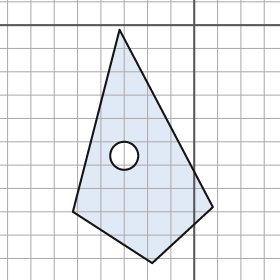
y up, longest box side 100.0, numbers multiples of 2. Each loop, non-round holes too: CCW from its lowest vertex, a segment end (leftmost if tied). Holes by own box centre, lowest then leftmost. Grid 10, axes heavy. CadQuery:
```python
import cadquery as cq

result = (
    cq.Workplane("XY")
    .moveTo(-18.0, -102.0)
    .lineTo(8.0, -78.0)
    .lineTo(-32.0, -2.0)
    .lineTo(-52.0, -80.0)
    .close()
    .moveTo(-30.0, -56.0)
    .circle(6.0)
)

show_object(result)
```